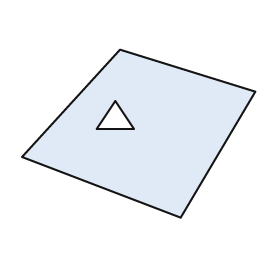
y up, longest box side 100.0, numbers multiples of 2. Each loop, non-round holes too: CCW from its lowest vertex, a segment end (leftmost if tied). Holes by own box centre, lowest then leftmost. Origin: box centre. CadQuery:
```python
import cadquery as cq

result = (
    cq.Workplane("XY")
    .moveTo(18.0, -36.0)
    .lineTo(50.0, 18.0)
    .lineTo(-8.0, 36.0)
    .lineTo(-50.0, -10.0)
    .close()
    .moveTo(-18.0, 2.0)
    .lineTo(-2.0, 2.0)
    .lineTo(-10.0, 14.0)
    .close()
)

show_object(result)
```